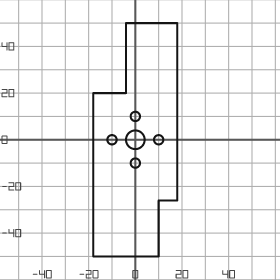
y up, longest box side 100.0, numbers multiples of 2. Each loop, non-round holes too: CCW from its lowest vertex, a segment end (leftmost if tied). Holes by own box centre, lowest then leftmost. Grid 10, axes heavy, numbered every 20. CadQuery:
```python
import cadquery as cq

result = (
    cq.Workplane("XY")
    .moveTo(-18.0, -50.0)
    .lineTo(10.0, -50.0)
    .lineTo(10.0, -26.0)
    .lineTo(18.0, -26.0)
    .lineTo(18.0, 50.0)
    .lineTo(-4.0, 50.0)
    .lineTo(-4.0, 20.0)
    .lineTo(-18.0, 20.0)
    .close()
    .moveTo(0.0, -10.0)
    .circle(2.0)
    .moveTo(-10.0, 0.0)
    .circle(2.0)
    .moveTo(0.0, 0.0)
    .circle(4.0)
    .moveTo(10.0, 0.0)
    .circle(2.0)
    .moveTo(0.0, 10.0)
    .circle(2.0)
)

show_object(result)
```